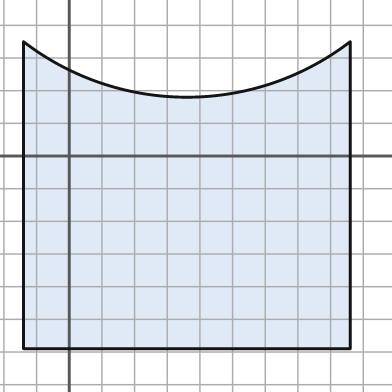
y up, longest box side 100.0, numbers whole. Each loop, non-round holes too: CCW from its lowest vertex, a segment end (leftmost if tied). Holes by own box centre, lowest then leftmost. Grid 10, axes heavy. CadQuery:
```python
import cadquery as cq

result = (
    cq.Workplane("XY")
    .moveTo(-14.0, -59.0)
    .lineTo(86.0, -59.0)
    .lineTo(86.0, 35.0)
    .threePointArc((36.0, 18.0), (-14.0, 35.0))
    .close()
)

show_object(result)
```